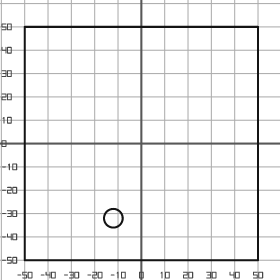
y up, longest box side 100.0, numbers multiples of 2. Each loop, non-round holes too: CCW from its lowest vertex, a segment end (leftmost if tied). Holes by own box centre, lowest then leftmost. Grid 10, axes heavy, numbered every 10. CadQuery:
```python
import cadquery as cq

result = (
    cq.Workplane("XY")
    .moveTo(-50.0, -50.0)
    .lineTo(50.0, -50.0)
    .lineTo(50.0, 50.0)
    .lineTo(-50.0, 50.0)
    .close()
    .moveTo(-12.0, -32.0)
    .circle(4.0)
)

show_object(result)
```